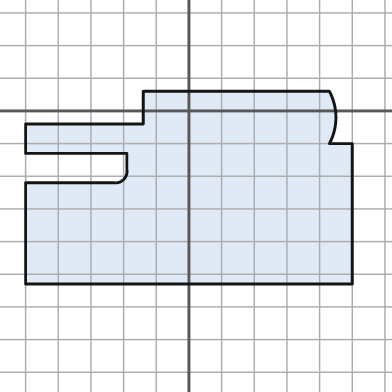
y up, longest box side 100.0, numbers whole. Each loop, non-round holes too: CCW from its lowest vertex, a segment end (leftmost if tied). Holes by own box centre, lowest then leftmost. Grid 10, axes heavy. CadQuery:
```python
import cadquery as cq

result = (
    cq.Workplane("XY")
    .moveTo(-50.0, -53.0)
    .lineTo(50.0, -53.0)
    .lineTo(50.0, -10.0)
    .lineTo(43.0, -10.0)
    .threePointArc((45.0, -2.0), (43.0, 6.0))
    .lineTo(-14.0, 6.0)
    .lineTo(-14.0, -4.0)
    .lineTo(-50.0, -4.0)
    .lineTo(-50.0, -13.0)
    .lineTo(-19.0, -13.0)
    .lineTo(-19.0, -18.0)
    .threePointArc((-20.0, -21.0), (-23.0, -22.0))
    .lineTo(-50.0, -22.0)
    .close()
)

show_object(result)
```